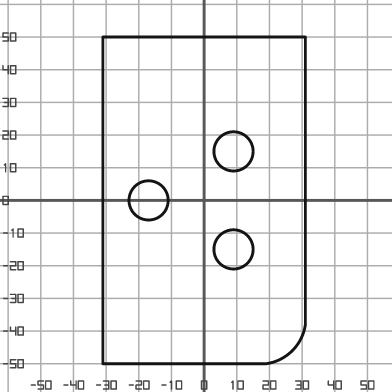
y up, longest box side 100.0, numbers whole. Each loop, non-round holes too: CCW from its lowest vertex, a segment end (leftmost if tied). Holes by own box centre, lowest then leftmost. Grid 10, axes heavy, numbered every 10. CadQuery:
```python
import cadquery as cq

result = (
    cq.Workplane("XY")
    .moveTo(-31.0, -50.0)
    .lineTo(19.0, -50.0)
    .threePointArc((27.0, -46.0), (31.0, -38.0))
    .lineTo(31.0, 50.0)
    .lineTo(-31.0, 50.0)
    .close()
    .moveTo(9.0, -15.0)
    .circle(6.0)
    .moveTo(-17.0, 0.0)
    .circle(6.0)
    .moveTo(9.0, 15.0)
    .circle(6.0)
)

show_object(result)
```